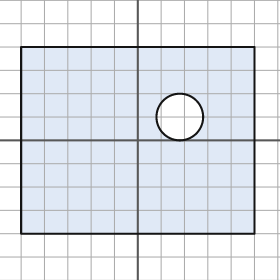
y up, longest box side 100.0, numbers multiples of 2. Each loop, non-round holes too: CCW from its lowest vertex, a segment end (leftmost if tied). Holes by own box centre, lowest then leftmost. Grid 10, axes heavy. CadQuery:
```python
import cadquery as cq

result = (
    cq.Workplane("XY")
    .moveTo(-50.0, -40.0)
    .lineTo(50.0, -40.0)
    .lineTo(50.0, 40.0)
    .lineTo(-50.0, 40.0)
    .close()
    .moveTo(18.0, 10.0)
    .circle(10.0)
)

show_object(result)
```